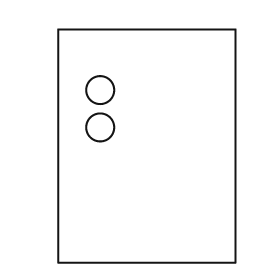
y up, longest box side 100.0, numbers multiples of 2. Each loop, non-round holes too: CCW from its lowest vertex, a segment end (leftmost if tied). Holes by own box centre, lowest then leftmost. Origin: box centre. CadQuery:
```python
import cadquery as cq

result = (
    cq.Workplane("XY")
    .moveTo(-38.0, -50.0)
    .lineTo(38.0, -50.0)
    .lineTo(38.0, 50.0)
    .lineTo(-38.0, 50.0)
    .close()
    .moveTo(-20.0, 8.0)
    .circle(6.0)
    .moveTo(-20.0, 24.0)
    .circle(6.0)
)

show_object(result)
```